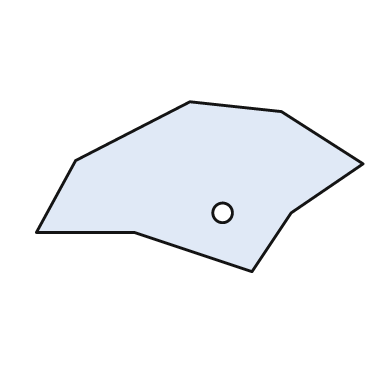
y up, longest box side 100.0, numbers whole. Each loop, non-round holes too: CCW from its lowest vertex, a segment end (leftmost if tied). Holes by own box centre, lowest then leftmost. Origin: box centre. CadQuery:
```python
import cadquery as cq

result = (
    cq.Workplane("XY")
    .moveTo(16.0, -26.0)
    .lineTo(28.0, -8.0)
    .lineTo(50.0, 7.0)
    .lineTo(25.0, 23.0)
    .lineTo(-3.0, 26.0)
    .lineTo(-38.0, 8.0)
    .lineTo(-50.0, -14.0)
    .lineTo(-20.0, -14.0)
    .close()
    .moveTo(7.0, -8.0)
    .circle(3.0)
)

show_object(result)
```